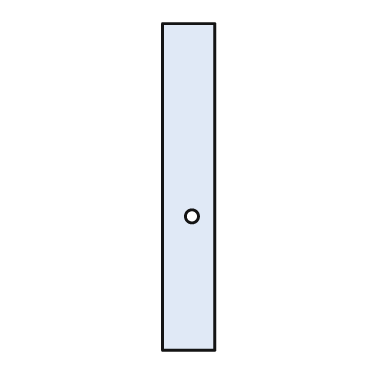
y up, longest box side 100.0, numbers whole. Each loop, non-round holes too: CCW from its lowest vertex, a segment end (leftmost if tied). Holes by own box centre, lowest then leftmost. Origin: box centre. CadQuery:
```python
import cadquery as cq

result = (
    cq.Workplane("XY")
    .moveTo(-8.0, -50.0)
    .lineTo(8.0, -50.0)
    .lineTo(8.0, 50.0)
    .lineTo(-8.0, 50.0)
    .close()
    .moveTo(1.0, -9.0)
    .circle(2.0)
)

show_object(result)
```